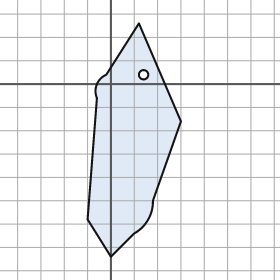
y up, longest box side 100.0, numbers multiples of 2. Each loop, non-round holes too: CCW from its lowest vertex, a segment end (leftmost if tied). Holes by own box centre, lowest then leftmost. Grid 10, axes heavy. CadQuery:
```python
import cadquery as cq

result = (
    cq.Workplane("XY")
    .moveTo(0.0, -74.0)
    .lineTo(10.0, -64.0)
    .threePointArc((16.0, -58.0), (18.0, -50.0))
    .lineTo(30.0, -16.0)
    .lineTo(12.0, 26.0)
    .lineTo(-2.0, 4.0)
    .threePointArc((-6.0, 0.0), (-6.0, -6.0))
    .lineTo(-10.0, -58.0)
    .close()
    .moveTo(14.0, 4.0)
    .circle(2.0)
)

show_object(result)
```